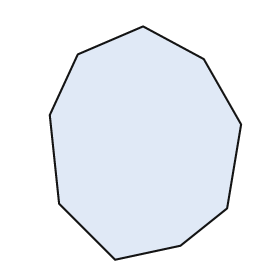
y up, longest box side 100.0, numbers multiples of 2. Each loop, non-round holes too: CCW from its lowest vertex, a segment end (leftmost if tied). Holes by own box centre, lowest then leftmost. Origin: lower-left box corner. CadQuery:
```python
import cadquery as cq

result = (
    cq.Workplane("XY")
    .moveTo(28.0, 0.0)
    .lineTo(56.0, 6.0)
    .lineTo(76.0, 22.0)
    .lineTo(82.0, 58.0)
    .lineTo(66.0, 86.0)
    .lineTo(40.0, 100.0)
    .lineTo(12.0, 88.0)
    .lineTo(0.0, 62.0)
    .lineTo(4.0, 24.0)
    .close()
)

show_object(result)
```